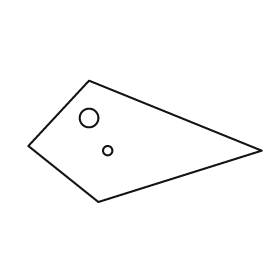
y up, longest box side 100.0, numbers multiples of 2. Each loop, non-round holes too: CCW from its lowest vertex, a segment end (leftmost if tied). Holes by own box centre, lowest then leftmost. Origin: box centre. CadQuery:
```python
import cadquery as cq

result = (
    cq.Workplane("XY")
    .moveTo(-20.0, -26.0)
    .lineTo(50.0, -4.0)
    .lineTo(-24.0, 26.0)
    .lineTo(-50.0, -2.0)
    .close()
    .moveTo(-16.0, -4.0)
    .circle(2.0)
    .moveTo(-24.0, 10.0)
    .circle(4.0)
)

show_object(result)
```